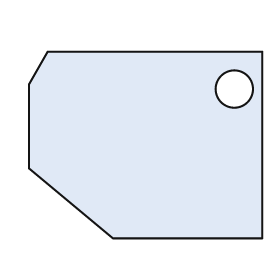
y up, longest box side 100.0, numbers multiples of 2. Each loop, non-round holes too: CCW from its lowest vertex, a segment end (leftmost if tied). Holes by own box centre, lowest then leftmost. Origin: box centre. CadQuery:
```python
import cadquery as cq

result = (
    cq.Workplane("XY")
    .moveTo(-14.0, -40.0)
    .lineTo(50.0, -40.0)
    .lineTo(50.0, 40.0)
    .lineTo(-42.0, 40.0)
    .lineTo(-50.0, 26.0)
    .lineTo(-50.0, -10.0)
    .close()
    .moveTo(38.0, 24.0)
    .circle(8.0)
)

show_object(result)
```